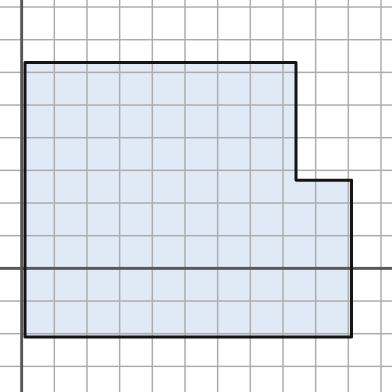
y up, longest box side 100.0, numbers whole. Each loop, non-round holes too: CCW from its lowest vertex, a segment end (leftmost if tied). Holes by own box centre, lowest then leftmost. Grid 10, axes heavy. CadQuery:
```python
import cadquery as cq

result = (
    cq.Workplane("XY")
    .moveTo(1.0, -21.0)
    .lineTo(101.0, -21.0)
    .lineTo(101.0, 27.0)
    .lineTo(84.0, 27.0)
    .lineTo(84.0, 63.0)
    .lineTo(1.0, 63.0)
    .close()
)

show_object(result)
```